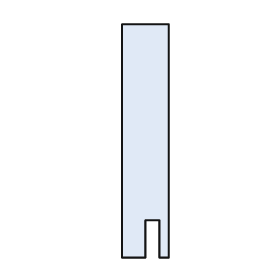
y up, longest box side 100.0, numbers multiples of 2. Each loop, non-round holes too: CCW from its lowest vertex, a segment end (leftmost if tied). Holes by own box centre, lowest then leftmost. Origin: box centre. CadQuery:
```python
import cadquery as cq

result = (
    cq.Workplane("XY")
    .moveTo(-10.0, -50.0)
    .lineTo(0.0, -50.0)
    .lineTo(0.0, -34.0)
    .lineTo(6.0, -34.0)
    .lineTo(6.0, -50.0)
    .lineTo(10.0, -50.0)
    .lineTo(10.0, 50.0)
    .lineTo(-10.0, 50.0)
    .close()
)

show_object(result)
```